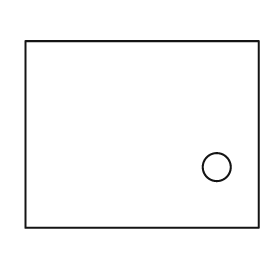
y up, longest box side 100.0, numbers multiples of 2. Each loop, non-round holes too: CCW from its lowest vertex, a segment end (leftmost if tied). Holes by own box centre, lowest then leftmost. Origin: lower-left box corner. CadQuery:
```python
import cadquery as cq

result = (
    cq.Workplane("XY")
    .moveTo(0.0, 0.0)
    .lineTo(100.0, 0.0)
    .lineTo(100.0, 80.0)
    .lineTo(0.0, 80.0)
    .close()
    .moveTo(82.0, 26.0)
    .circle(6.0)
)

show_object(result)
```